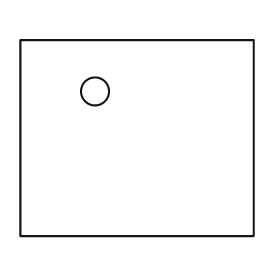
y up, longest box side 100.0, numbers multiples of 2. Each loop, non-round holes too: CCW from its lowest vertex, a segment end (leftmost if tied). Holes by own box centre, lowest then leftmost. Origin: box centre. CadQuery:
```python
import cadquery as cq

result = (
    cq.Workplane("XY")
    .moveTo(-50.0, -42.0)
    .lineTo(50.0, -42.0)
    .lineTo(50.0, 42.0)
    .lineTo(-50.0, 42.0)
    .close()
    .moveTo(-18.0, 20.0)
    .circle(6.0)
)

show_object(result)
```